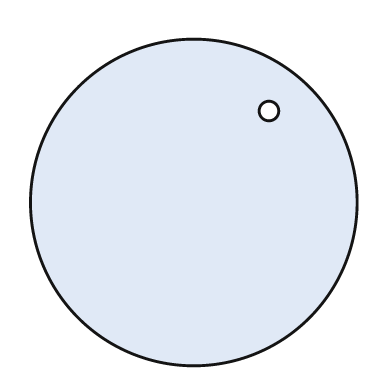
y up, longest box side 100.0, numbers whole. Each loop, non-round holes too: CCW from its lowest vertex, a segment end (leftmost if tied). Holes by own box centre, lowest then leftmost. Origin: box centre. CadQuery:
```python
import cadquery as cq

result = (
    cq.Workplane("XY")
    .moveTo(0.0, 0.0)
    .circle(50.0)
    .moveTo(23.0, 28.0)
    .circle(3.0)
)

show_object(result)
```